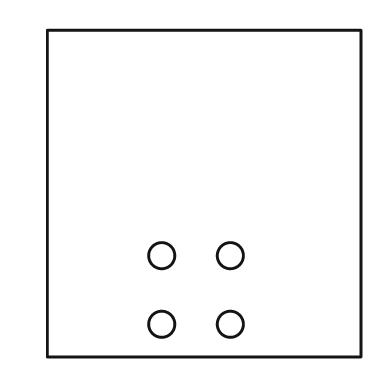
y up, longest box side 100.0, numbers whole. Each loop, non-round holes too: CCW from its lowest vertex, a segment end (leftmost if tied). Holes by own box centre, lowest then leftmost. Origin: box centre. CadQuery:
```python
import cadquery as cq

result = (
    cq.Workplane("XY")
    .moveTo(-48.0, -50.0)
    .lineTo(48.0, -50.0)
    .lineTo(48.0, 50.0)
    .lineTo(-48.0, 50.0)
    .close()
    .moveTo(-13.0, -40.0)
    .circle(4.0)
    .moveTo(8.0, -40.0)
    .circle(4.0)
    .moveTo(-13.0, -19.0)
    .circle(4.0)
    .moveTo(8.0, -19.0)
    .circle(4.0)
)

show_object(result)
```